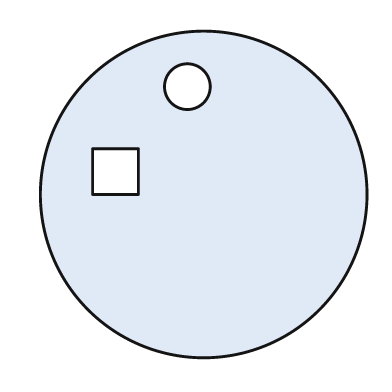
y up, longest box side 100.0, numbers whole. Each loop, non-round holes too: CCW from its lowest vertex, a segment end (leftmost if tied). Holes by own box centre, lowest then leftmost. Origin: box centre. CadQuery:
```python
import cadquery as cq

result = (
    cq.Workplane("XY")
    .moveTo(0.0, 0.0)
    .circle(50.0)
    .moveTo(-34.0, 0.0)
    .lineTo(-20.0, 0.0)
    .lineTo(-20.0, 14.0)
    .lineTo(-34.0, 14.0)
    .close()
    .moveTo(-5.0, 33.0)
    .circle(7.0)
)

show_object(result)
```